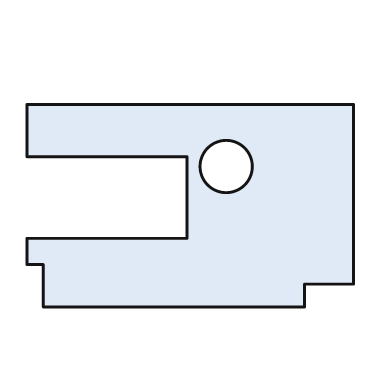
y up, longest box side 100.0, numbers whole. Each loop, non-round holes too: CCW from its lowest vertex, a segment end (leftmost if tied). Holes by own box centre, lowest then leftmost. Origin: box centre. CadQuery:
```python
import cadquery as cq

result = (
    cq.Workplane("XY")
    .moveTo(-45.0, -31.0)
    .lineTo(35.0, -31.0)
    .lineTo(35.0, -24.0)
    .lineTo(50.0, -24.0)
    .lineTo(50.0, 31.0)
    .lineTo(-50.0, 31.0)
    .lineTo(-50.0, 15.0)
    .lineTo(-1.0, 15.0)
    .lineTo(-1.0, -10.0)
    .lineTo(-50.0, -10.0)
    .lineTo(-50.0, -18.0)
    .lineTo(-45.0, -18.0)
    .close()
    .moveTo(11.0, 12.0)
    .circle(8.0)
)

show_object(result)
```